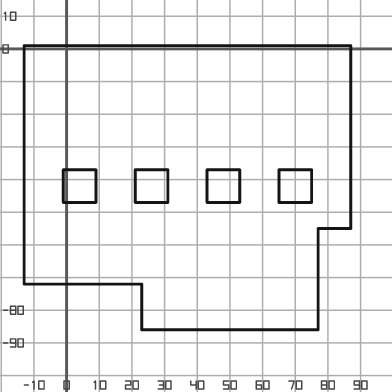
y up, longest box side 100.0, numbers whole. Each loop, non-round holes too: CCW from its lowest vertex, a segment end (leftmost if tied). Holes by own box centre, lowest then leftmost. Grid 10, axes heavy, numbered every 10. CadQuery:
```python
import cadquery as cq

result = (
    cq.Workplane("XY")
    .moveTo(23.0, -86.0)
    .lineTo(77.0, -86.0)
    .lineTo(77.0, -55.0)
    .lineTo(87.0, -55.0)
    .lineTo(87.0, 1.0)
    .lineTo(-13.0, 1.0)
    .lineTo(-13.0, -72.0)
    .lineTo(23.0, -72.0)
    .close()
    .moveTo(-1.0, -47.0)
    .lineTo(9.0, -47.0)
    .lineTo(9.0, -37.0)
    .lineTo(-1.0, -37.0)
    .close()
    .moveTo(21.0, -47.0)
    .lineTo(31.0, -47.0)
    .lineTo(31.0, -37.0)
    .lineTo(21.0, -37.0)
    .close()
    .moveTo(43.0, -47.0)
    .lineTo(53.0, -47.0)
    .lineTo(53.0, -37.0)
    .lineTo(43.0, -37.0)
    .close()
    .moveTo(65.0, -47.0)
    .lineTo(75.0, -47.0)
    .lineTo(75.0, -37.0)
    .lineTo(65.0, -37.0)
    .close()
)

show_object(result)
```